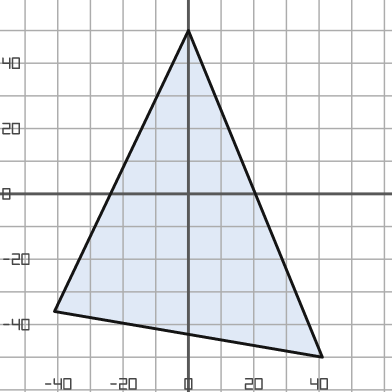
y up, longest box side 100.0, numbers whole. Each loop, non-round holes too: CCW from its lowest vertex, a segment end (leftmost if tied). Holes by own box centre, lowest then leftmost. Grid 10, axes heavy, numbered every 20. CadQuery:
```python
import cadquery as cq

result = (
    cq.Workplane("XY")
    .moveTo(41.0, -50.0)
    .lineTo(0.0, 50.0)
    .lineTo(-41.0, -36.0)
    .close()
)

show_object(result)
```